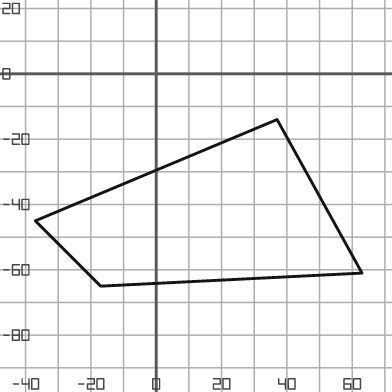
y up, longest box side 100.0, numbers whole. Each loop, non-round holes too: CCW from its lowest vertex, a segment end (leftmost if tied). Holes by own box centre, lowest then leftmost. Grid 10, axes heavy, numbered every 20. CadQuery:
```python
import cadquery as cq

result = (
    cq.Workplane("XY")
    .moveTo(-17.0, -65.0)
    .lineTo(63.0, -61.0)
    .lineTo(37.0, -14.0)
    .lineTo(-37.0, -45.0)
    .close()
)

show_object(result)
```